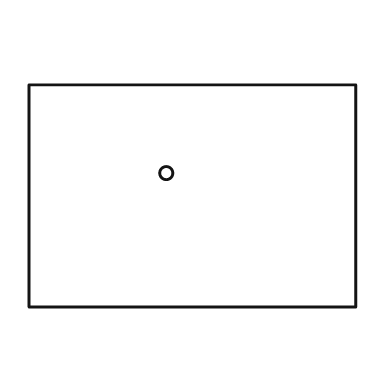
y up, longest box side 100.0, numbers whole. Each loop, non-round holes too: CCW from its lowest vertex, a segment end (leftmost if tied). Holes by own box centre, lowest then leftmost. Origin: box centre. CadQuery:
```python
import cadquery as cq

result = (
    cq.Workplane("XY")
    .moveTo(-50.0, -34.0)
    .lineTo(50.0, -34.0)
    .lineTo(50.0, 34.0)
    .lineTo(-50.0, 34.0)
    .close()
    .moveTo(-8.0, 7.0)
    .circle(2.0)
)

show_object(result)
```